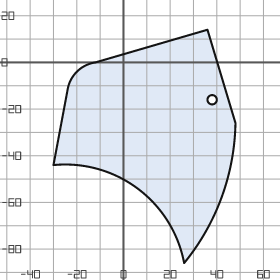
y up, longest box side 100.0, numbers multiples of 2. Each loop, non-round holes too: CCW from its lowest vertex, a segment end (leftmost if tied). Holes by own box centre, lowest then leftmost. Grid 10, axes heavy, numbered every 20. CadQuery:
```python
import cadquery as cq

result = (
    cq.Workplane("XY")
    .moveTo(26.0, -86.0)
    .threePointArc((42.0, -58.0), (48.0, -26.0))
    .lineTo(36.0, 14.0)
    .lineTo(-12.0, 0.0)
    .threePointArc((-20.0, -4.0), (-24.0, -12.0))
    .lineTo(-30.0, -44.0)
    .threePointArc((6.0, -54.0), (26.0, -86.0))
    .close()
    .moveTo(38.0, -16.0)
    .circle(2.0)
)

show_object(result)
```